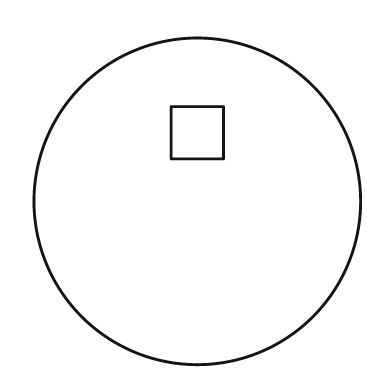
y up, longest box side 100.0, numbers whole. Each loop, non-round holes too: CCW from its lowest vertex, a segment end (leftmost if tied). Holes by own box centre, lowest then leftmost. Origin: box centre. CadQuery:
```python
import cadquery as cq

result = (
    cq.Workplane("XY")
    .moveTo(0.0, 0.0)
    .circle(50.0)
    .moveTo(-8.0, 13.0)
    .lineTo(8.0, 13.0)
    .lineTo(8.0, 29.0)
    .lineTo(-8.0, 29.0)
    .close()
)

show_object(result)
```